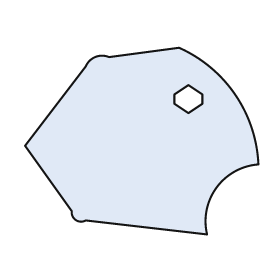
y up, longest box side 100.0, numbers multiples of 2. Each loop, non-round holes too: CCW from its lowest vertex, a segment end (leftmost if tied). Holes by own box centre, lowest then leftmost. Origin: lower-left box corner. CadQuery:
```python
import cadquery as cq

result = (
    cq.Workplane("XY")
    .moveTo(78.0, 0.0)
    .threePointArc((82.0, 20.0), (100.0, 30.0))
    .threePointArc((90.0, 60.0), (66.0, 80.0))
    .lineTo(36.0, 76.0)
    .threePointArc((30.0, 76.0), (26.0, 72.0))
    .lineTo(0.0, 38.0)
    .lineTo(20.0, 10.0)
    .threePointArc((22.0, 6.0), (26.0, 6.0))
    .close()
    .moveTo(70.0, 52.0)
    .lineTo(76.0, 56.0)
    .lineTo(76.0, 60.0)
    .lineTo(70.0, 64.0)
    .lineTo(64.0, 60.0)
    .lineTo(64.0, 56.0)
    .close()
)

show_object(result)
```